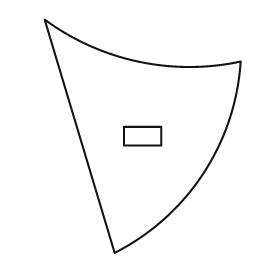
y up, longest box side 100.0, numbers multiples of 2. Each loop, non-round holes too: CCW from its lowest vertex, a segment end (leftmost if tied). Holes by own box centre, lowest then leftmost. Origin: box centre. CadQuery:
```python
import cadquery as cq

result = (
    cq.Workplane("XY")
    .moveTo(-12.0, -50.0)
    .threePointArc((26.0, -16.0), (42.0, 32.0))
    .threePointArc((-2.0, 32.0), (-42.0, 50.0))
    .close()
    .moveTo(-8.0, -4.0)
    .lineTo(8.0, -4.0)
    .lineTo(8.0, 4.0)
    .lineTo(-8.0, 4.0)
    .close()
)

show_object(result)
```